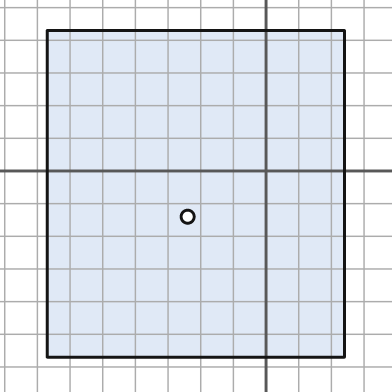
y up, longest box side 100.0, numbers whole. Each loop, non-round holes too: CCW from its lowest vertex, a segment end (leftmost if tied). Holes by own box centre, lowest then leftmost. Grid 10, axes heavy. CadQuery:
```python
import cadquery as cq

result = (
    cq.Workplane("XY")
    .moveTo(-67.0, -57.0)
    .lineTo(24.0, -57.0)
    .lineTo(24.0, 43.0)
    .lineTo(-67.0, 43.0)
    .close()
    .moveTo(-24.0, -14.0)
    .circle(2.0)
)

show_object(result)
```